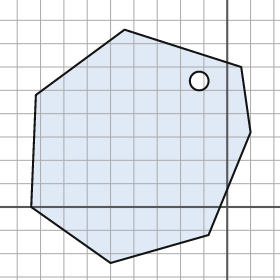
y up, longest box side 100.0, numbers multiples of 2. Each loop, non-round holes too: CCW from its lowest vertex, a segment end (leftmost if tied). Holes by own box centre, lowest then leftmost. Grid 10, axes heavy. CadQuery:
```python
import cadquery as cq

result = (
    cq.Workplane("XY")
    .moveTo(-50.0, -24.0)
    .lineTo(-8.0, -12.0)
    .lineTo(10.0, 32.0)
    .lineTo(6.0, 60.0)
    .lineTo(-44.0, 76.0)
    .lineTo(-82.0, 48.0)
    .lineTo(-84.0, 0.0)
    .close()
    .moveTo(-12.0, 54.0)
    .circle(4.0)
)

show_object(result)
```